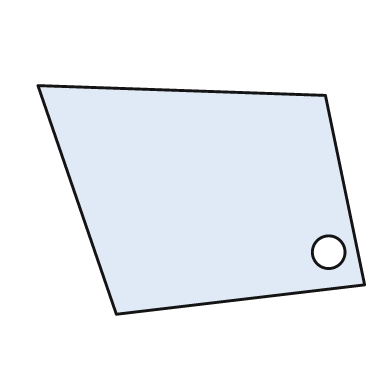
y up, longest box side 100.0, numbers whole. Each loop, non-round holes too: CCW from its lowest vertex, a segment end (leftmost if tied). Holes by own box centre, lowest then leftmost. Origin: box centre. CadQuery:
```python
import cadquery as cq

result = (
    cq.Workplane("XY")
    .moveTo(-26.0, -35.0)
    .lineTo(50.0, -26.0)
    .lineTo(38.0, 32.0)
    .lineTo(-50.0, 35.0)
    .close()
    .moveTo(39.0, -16.0)
    .circle(5.0)
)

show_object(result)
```